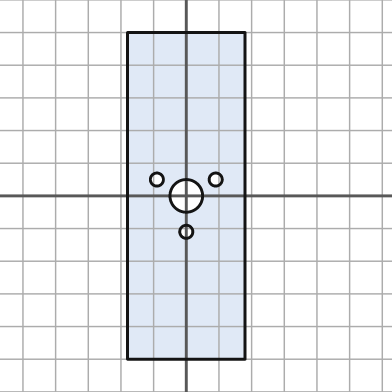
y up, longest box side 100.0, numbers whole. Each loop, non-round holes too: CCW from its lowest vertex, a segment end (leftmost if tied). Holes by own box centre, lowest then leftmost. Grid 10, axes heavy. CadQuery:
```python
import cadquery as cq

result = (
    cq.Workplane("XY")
    .moveTo(-18.0, -50.0)
    .lineTo(18.0, -50.0)
    .lineTo(18.0, 50.0)
    .lineTo(-18.0, 50.0)
    .close()
    .moveTo(0.0, -11.0)
    .circle(2.0)
    .moveTo(0.0, 0.0)
    .circle(5.0)
    .moveTo(-9.0, 5.0)
    .circle(2.0)
    .moveTo(9.0, 5.0)
    .circle(2.0)
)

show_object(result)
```